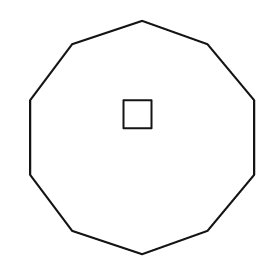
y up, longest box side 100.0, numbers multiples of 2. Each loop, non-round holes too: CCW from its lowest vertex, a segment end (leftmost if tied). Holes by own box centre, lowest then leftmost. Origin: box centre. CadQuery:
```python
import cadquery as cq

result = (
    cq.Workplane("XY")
    .moveTo(0.0, -50.0)
    .lineTo(28.0, -40.0)
    .lineTo(48.0, -16.0)
    .lineTo(48.0, 16.0)
    .lineTo(28.0, 40.0)
    .lineTo(0.0, 50.0)
    .lineTo(-30.0, 40.0)
    .lineTo(-48.0, 16.0)
    .lineTo(-48.0, -16.0)
    .lineTo(-30.0, -40.0)
    .close()
    .moveTo(-8.0, 4.0)
    .lineTo(4.0, 4.0)
    .lineTo(4.0, 16.0)
    .lineTo(-8.0, 16.0)
    .close()
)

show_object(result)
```